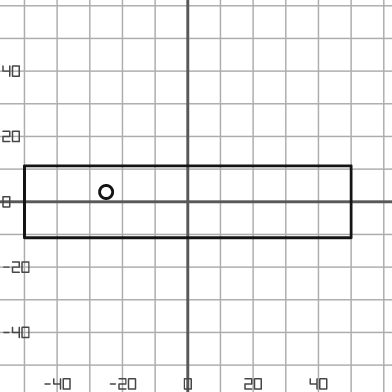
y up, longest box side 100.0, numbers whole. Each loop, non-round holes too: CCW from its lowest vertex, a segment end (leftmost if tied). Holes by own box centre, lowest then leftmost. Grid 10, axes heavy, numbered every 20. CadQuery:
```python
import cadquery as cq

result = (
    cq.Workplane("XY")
    .moveTo(-50.0, -11.0)
    .lineTo(50.0, -11.0)
    .lineTo(50.0, 11.0)
    .lineTo(-50.0, 11.0)
    .close()
    .moveTo(-25.0, 3.0)
    .circle(2.0)
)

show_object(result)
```